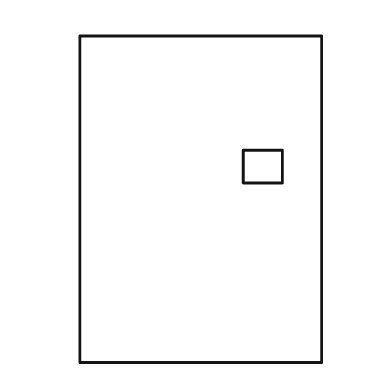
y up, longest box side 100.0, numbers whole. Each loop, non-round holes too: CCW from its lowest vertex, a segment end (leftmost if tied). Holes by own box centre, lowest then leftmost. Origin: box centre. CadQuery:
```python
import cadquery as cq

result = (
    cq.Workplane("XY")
    .moveTo(-37.0, -50.0)
    .lineTo(37.0, -50.0)
    .lineTo(37.0, 50.0)
    .lineTo(-37.0, 50.0)
    .close()
    .moveTo(13.0, 5.0)
    .lineTo(25.0, 5.0)
    .lineTo(25.0, 15.0)
    .lineTo(13.0, 15.0)
    .close()
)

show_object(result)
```